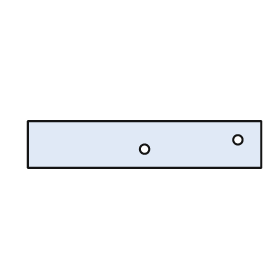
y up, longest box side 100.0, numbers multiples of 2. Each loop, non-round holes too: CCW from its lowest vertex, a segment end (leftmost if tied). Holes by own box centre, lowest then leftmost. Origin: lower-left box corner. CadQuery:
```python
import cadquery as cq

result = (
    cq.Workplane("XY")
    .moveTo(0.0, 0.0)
    .lineTo(100.0, 0.0)
    .lineTo(100.0, 20.0)
    .lineTo(0.0, 20.0)
    .close()
    .moveTo(50.0, 8.0)
    .circle(2.0)
    .moveTo(90.0, 12.0)
    .circle(2.0)
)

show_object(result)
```